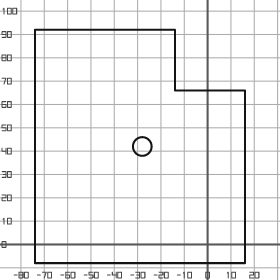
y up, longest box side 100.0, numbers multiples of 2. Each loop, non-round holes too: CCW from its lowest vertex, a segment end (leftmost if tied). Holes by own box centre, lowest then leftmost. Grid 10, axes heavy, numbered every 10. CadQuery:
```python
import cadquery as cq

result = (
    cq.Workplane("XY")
    .moveTo(-74.0, -8.0)
    .lineTo(16.0, -8.0)
    .lineTo(16.0, 66.0)
    .lineTo(-14.0, 66.0)
    .lineTo(-14.0, 92.0)
    .lineTo(-74.0, 92.0)
    .close()
    .moveTo(-28.0, 42.0)
    .circle(4.0)
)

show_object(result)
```